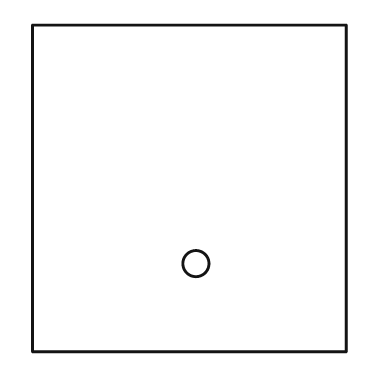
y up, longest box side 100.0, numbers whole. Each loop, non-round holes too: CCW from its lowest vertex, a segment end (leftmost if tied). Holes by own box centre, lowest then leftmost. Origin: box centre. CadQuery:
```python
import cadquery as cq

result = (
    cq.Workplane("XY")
    .moveTo(-48.0, -50.0)
    .lineTo(48.0, -50.0)
    .lineTo(48.0, 50.0)
    .lineTo(-48.0, 50.0)
    .close()
    .moveTo(2.0, -23.0)
    .circle(4.0)
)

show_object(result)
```